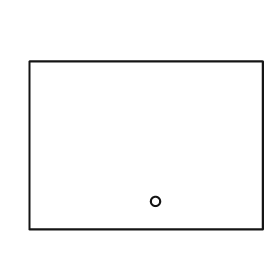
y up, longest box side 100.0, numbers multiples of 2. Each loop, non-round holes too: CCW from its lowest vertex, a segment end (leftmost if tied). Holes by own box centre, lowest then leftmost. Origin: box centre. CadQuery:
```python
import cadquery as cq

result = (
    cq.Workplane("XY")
    .moveTo(-50.0, -36.0)
    .lineTo(50.0, -36.0)
    .lineTo(50.0, 36.0)
    .lineTo(-50.0, 36.0)
    .close()
    .moveTo(4.0, -24.0)
    .circle(2.0)
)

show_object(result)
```